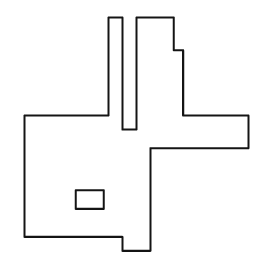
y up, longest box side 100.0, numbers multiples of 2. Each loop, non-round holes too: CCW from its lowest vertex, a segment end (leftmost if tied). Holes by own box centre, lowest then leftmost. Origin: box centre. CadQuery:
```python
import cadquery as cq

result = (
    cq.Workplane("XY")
    .moveTo(-6.0, -50.0)
    .lineTo(6.0, -50.0)
    .lineTo(6.0, -6.0)
    .lineTo(48.0, -6.0)
    .lineTo(48.0, 8.0)
    .lineTo(20.0, 8.0)
    .lineTo(20.0, 36.0)
    .lineTo(16.0, 36.0)
    .lineTo(16.0, 50.0)
    .lineTo(0.0, 50.0)
    .lineTo(0.0, 2.0)
    .lineTo(-6.0, 2.0)
    .lineTo(-6.0, 50.0)
    .lineTo(-12.0, 50.0)
    .lineTo(-12.0, 8.0)
    .lineTo(-48.0, 8.0)
    .lineTo(-48.0, -44.0)
    .lineTo(-6.0, -44.0)
    .close()
    .moveTo(-26.0, -32.0)
    .lineTo(-14.0, -32.0)
    .lineTo(-14.0, -24.0)
    .lineTo(-26.0, -24.0)
    .close()
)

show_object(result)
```